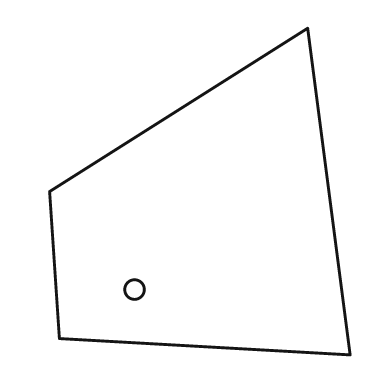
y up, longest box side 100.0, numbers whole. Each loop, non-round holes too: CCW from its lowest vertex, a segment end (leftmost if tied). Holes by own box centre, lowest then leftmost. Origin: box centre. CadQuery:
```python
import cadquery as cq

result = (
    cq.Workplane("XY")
    .moveTo(46.0, -50.0)
    .lineTo(33.0, 50.0)
    .lineTo(-46.0, 0.0)
    .lineTo(-43.0, -45.0)
    .close()
    .moveTo(-20.0, -30.0)
    .circle(3.0)
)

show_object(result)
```